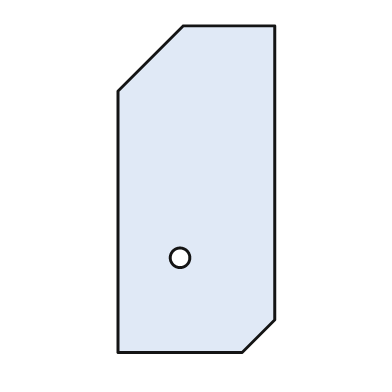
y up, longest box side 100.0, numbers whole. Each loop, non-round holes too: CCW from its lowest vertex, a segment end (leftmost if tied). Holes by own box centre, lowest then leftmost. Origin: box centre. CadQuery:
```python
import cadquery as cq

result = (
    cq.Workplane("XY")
    .moveTo(-24.0, -50.0)
    .lineTo(14.0, -50.0)
    .lineTo(24.0, -40.0)
    .lineTo(24.0, 50.0)
    .lineTo(-4.0, 50.0)
    .lineTo(-24.0, 30.0)
    .close()
    .moveTo(-5.0, -21.0)
    .circle(3.0)
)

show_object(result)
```